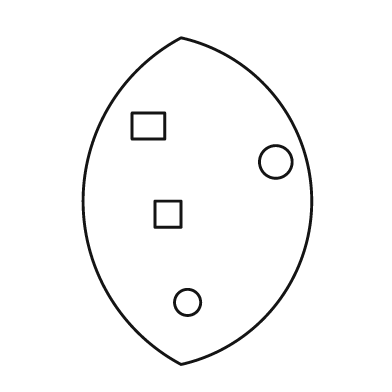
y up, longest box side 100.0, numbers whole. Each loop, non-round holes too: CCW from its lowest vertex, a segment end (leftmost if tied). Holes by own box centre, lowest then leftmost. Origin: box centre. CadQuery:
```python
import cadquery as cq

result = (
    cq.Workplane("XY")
    .moveTo(-5.0, -50.0)
    .threePointArc((35.0, 0.0), (-5.0, 50.0))
    .threePointArc((-35.0, 0.0), (-5.0, -50.0))
    .close()
    .moveTo(-3.0, -31.0)
    .circle(4.0)
    .moveTo(-13.0, -8.0)
    .lineTo(-5.0, -8.0)
    .lineTo(-5.0, 0.0)
    .lineTo(-13.0, 0.0)
    .close()
    .moveTo(24.0, 12.0)
    .circle(5.0)
    .moveTo(-20.0, 19.0)
    .lineTo(-10.0, 19.0)
    .lineTo(-10.0, 27.0)
    .lineTo(-20.0, 27.0)
    .close()
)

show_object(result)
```